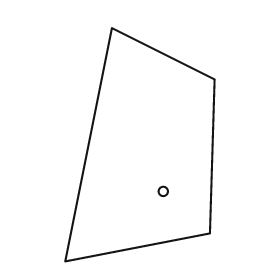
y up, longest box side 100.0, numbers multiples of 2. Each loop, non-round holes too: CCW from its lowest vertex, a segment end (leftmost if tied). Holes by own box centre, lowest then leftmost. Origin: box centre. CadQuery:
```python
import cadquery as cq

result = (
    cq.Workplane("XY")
    .moveTo(-32.0, -50.0)
    .lineTo(30.0, -38.0)
    .lineTo(32.0, 28.0)
    .lineTo(-12.0, 50.0)
    .close()
    .moveTo(10.0, -20.0)
    .circle(2.0)
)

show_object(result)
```